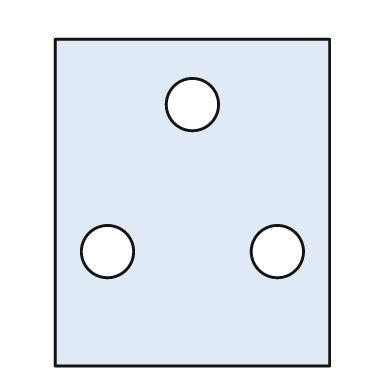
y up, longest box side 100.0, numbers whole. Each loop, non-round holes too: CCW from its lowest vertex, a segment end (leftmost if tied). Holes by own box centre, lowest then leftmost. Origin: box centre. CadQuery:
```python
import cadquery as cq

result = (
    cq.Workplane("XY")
    .moveTo(-42.0, -50.0)
    .lineTo(42.0, -50.0)
    .lineTo(42.0, 50.0)
    .lineTo(-42.0, 50.0)
    .close()
    .moveTo(-26.0, -15.0)
    .circle(8.0)
    .moveTo(26.0, -15.0)
    .circle(8.0)
    .moveTo(0.0, 30.0)
    .circle(8.0)
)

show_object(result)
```